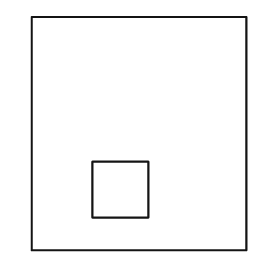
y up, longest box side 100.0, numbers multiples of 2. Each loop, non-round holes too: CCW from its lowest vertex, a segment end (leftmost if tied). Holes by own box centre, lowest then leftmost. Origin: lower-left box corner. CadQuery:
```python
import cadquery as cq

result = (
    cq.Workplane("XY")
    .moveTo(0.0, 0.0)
    .lineTo(92.0, 0.0)
    .lineTo(92.0, 100.0)
    .lineTo(0.0, 100.0)
    .close()
    .moveTo(26.0, 14.0)
    .lineTo(50.0, 14.0)
    .lineTo(50.0, 38.0)
    .lineTo(26.0, 38.0)
    .close()
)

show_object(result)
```